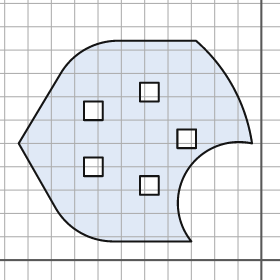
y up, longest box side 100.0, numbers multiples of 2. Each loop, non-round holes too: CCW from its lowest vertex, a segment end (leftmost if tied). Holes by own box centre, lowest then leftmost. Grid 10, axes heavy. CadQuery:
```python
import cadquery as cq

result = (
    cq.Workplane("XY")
    .moveTo(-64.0, 8.0)
    .lineTo(-30.0, 8.0)
    .threePointArc((-32.0, 38.0), (-4.0, 50.0))
    .threePointArc((-12.0, 74.0), (-28.0, 94.0))
    .lineTo(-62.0, 94.0)
    .threePointArc((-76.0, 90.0), (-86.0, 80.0))
    .lineTo(-104.0, 50.0)
    .lineTo(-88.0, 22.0)
    .threePointArc((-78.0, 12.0), (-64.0, 8.0))
    .close()
    .moveTo(-52.0, 28.0)
    .lineTo(-44.0, 28.0)
    .lineTo(-44.0, 36.0)
    .lineTo(-52.0, 36.0)
    .close()
    .moveTo(-76.0, 36.0)
    .lineTo(-68.0, 36.0)
    .lineTo(-68.0, 44.0)
    .lineTo(-76.0, 44.0)
    .close()
    .moveTo(-36.0, 48.0)
    .lineTo(-28.0, 48.0)
    .lineTo(-28.0, 56.0)
    .lineTo(-36.0, 56.0)
    .close()
    .moveTo(-76.0, 60.0)
    .lineTo(-68.0, 60.0)
    .lineTo(-68.0, 68.0)
    .lineTo(-76.0, 68.0)
    .close()
    .moveTo(-52.0, 68.0)
    .lineTo(-44.0, 68.0)
    .lineTo(-44.0, 76.0)
    .lineTo(-52.0, 76.0)
    .close()
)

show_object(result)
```